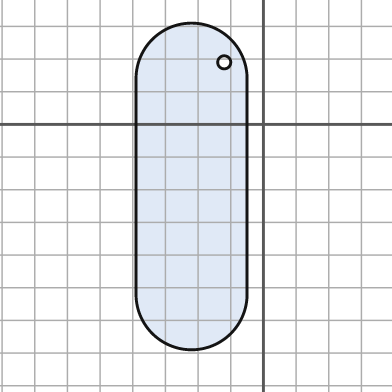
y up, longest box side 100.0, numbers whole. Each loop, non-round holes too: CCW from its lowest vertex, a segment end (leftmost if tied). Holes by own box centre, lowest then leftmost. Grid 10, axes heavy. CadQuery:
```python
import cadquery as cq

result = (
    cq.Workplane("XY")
    .moveTo(-39.0, -52.0)
    .threePointArc((-22.0, -69.0), (-5.0, -52.0))
    .lineTo(-5.0, 14.0)
    .threePointArc((-22.0, 31.0), (-39.0, 14.0))
    .close()
    .moveTo(-12.0, 19.0)
    .circle(2.0)
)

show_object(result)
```